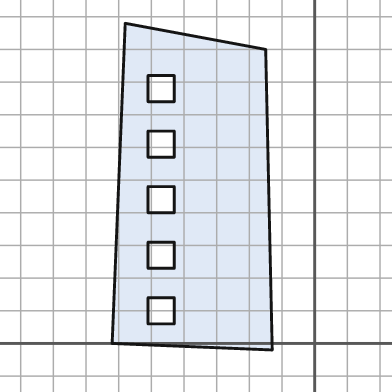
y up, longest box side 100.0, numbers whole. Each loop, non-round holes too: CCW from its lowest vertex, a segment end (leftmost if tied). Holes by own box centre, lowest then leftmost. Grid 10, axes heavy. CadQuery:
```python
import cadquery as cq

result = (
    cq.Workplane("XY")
    .moveTo(-13.0, -2.0)
    .lineTo(-15.0, 90.0)
    .lineTo(-58.0, 98.0)
    .lineTo(-62.0, 0.0)
    .close()
    .moveTo(-51.0, 6.0)
    .lineTo(-43.0, 6.0)
    .lineTo(-43.0, 14.0)
    .lineTo(-51.0, 14.0)
    .close()
    .moveTo(-51.0, 23.0)
    .lineTo(-43.0, 23.0)
    .lineTo(-43.0, 31.0)
    .lineTo(-51.0, 31.0)
    .close()
    .moveTo(-51.0, 40.0)
    .lineTo(-43.0, 40.0)
    .lineTo(-43.0, 48.0)
    .lineTo(-51.0, 48.0)
    .close()
    .moveTo(-51.0, 57.0)
    .lineTo(-43.0, 57.0)
    .lineTo(-43.0, 65.0)
    .lineTo(-51.0, 65.0)
    .close()
    .moveTo(-51.0, 74.0)
    .lineTo(-43.0, 74.0)
    .lineTo(-43.0, 82.0)
    .lineTo(-51.0, 82.0)
    .close()
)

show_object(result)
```